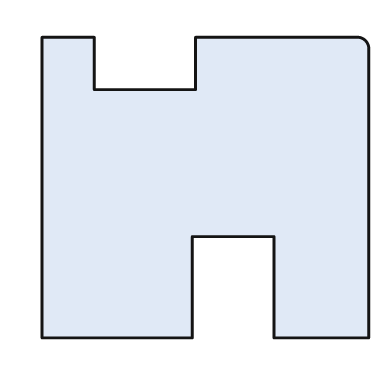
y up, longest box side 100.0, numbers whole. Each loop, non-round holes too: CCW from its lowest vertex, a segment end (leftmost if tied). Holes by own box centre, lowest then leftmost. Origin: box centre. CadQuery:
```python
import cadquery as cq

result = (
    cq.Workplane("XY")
    .moveTo(-50.0, -46.0)
    .lineTo(-4.0, -46.0)
    .lineTo(-4.0, -15.0)
    .lineTo(21.0, -15.0)
    .lineTo(21.0, -46.0)
    .lineTo(50.0, -46.0)
    .lineTo(50.0, 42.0)
    .threePointArc((49.0, 45.0), (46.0, 46.0))
    .lineTo(-3.0, 46.0)
    .lineTo(-3.0, 30.0)
    .lineTo(-34.0, 30.0)
    .lineTo(-34.0, 46.0)
    .lineTo(-50.0, 46.0)
    .close()
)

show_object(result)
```